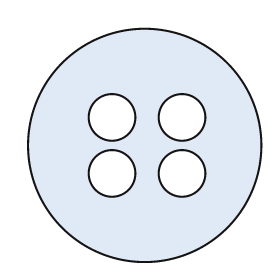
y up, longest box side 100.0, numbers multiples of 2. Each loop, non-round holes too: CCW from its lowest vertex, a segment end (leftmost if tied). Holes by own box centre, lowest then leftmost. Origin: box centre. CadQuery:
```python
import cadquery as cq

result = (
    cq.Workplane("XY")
    .moveTo(0.0, 0.0)
    .circle(50.0)
    .moveTo(-14.0, -12.0)
    .circle(10.0)
    .moveTo(16.0, -12.0)
    .circle(10.0)
    .moveTo(-14.0, 12.0)
    .circle(10.0)
    .moveTo(16.0, 12.0)
    .circle(10.0)
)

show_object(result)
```